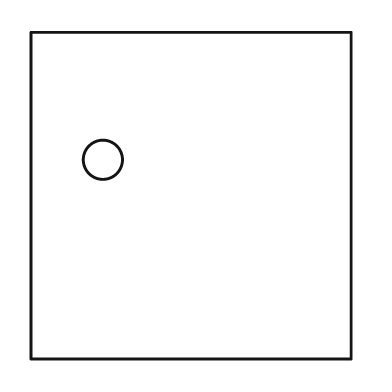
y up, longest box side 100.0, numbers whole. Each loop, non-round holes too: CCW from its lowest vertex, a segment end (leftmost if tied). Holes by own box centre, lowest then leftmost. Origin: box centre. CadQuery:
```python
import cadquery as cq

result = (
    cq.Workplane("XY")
    .moveTo(-49.0, -50.0)
    .lineTo(49.0, -50.0)
    .lineTo(49.0, 50.0)
    .lineTo(-49.0, 50.0)
    .close()
    .moveTo(-27.0, 11.0)
    .circle(6.0)
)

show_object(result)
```